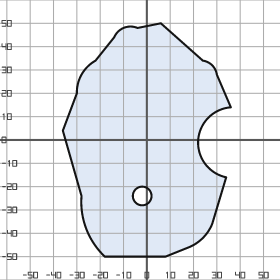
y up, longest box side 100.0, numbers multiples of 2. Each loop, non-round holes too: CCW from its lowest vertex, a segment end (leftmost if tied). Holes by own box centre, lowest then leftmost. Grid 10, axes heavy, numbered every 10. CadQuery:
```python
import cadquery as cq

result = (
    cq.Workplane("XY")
    .moveTo(-18.0, -50.0)
    .lineTo(8.0, -50.0)
    .lineTo(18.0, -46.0)
    .threePointArc((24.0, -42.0), (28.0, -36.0))
    .lineTo(34.0, -16.0)
    .threePointArc((22.0, 0.0), (36.0, 14.0))
    .lineTo(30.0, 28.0)
    .threePointArc((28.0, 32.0), (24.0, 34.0))
    .lineTo(6.0, 50.0)
    .lineTo(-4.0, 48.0)
    .threePointArc((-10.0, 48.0), (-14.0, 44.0))
    .lineTo(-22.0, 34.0)
    .threePointArc((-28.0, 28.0), (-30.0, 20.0))
    .lineTo(-36.0, 4.0)
    .lineTo(-28.0, -24.0)
    .threePointArc((-26.0, -38.0), (-18.0, -50.0))
    .close()
    .moveTo(-2.0, -24.0)
    .circle(4.0)
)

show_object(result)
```